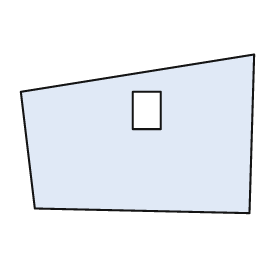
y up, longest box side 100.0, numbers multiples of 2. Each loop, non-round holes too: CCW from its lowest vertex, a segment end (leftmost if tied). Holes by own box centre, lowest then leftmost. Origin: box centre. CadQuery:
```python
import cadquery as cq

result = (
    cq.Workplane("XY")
    .moveTo(48.0, -34.0)
    .lineTo(50.0, 34.0)
    .lineTo(-50.0, 18.0)
    .lineTo(-44.0, -32.0)
    .close()
    .moveTo(-2.0, 2.0)
    .lineTo(10.0, 2.0)
    .lineTo(10.0, 18.0)
    .lineTo(-2.0, 18.0)
    .close()
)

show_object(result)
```